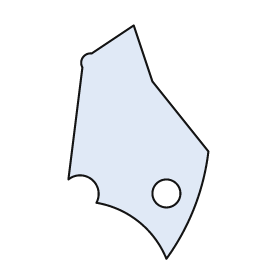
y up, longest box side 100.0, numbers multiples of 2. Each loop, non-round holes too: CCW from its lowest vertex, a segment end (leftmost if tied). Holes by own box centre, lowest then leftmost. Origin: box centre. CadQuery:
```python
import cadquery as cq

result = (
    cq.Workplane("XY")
    .moveTo(12.0, -50.0)
    .threePointArc((24.0, -28.0), (30.0, -4.0))
    .lineTo(6.0, 26.0)
    .lineTo(-2.0, 50.0)
    .lineTo(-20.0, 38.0)
    .threePointArc((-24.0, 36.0), (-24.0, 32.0))
    .lineTo(-30.0, -16.0)
    .threePointArc((-20.0, -16.0), (-18.0, -26.0))
    .threePointArc((0.0, -34.0), (12.0, -50.0))
    .close()
    .moveTo(12.0, -22.0)
    .circle(6.0)
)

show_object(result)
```